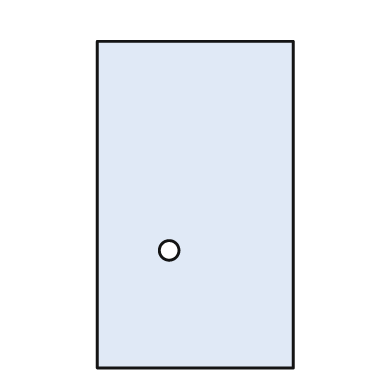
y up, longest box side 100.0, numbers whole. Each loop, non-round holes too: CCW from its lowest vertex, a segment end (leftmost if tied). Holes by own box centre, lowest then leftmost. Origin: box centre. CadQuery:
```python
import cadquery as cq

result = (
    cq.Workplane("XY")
    .moveTo(-30.0, -50.0)
    .lineTo(30.0, -50.0)
    .lineTo(30.0, 50.0)
    .lineTo(-30.0, 50.0)
    .close()
    .moveTo(-8.0, -14.0)
    .circle(3.0)
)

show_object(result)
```